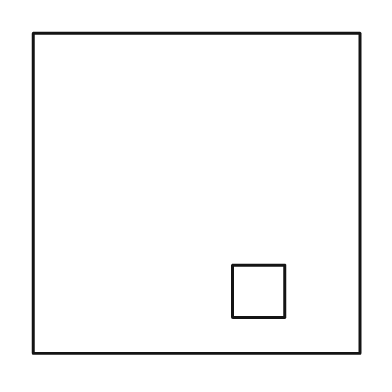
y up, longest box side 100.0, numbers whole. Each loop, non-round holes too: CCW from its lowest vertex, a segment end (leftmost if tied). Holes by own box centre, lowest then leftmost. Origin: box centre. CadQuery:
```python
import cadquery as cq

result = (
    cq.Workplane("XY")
    .moveTo(-50.0, -49.0)
    .lineTo(50.0, -49.0)
    .lineTo(50.0, 49.0)
    .lineTo(-50.0, 49.0)
    .close()
    .moveTo(11.0, -38.0)
    .lineTo(27.0, -38.0)
    .lineTo(27.0, -22.0)
    .lineTo(11.0, -22.0)
    .close()
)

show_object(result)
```